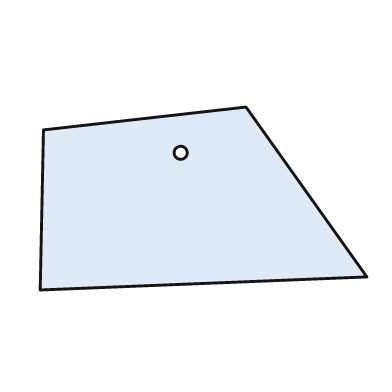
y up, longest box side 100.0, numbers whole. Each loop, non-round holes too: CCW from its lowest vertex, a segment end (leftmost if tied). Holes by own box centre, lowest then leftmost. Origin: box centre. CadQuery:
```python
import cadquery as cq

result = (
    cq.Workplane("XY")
    .moveTo(-50.0, -28.0)
    .lineTo(50.0, -24.0)
    .lineTo(13.0, 28.0)
    .lineTo(-49.0, 21.0)
    .close()
    .moveTo(-7.0, 14.0)
    .circle(2.0)
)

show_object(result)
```